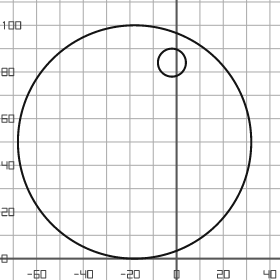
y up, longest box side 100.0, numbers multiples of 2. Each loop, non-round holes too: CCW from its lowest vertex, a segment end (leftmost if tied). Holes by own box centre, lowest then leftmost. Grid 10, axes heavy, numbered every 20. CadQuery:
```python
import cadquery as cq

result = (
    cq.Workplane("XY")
    .moveTo(-18.0, 50.0)
    .circle(50.0)
    .moveTo(-2.0, 84.0)
    .circle(6.0)
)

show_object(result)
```